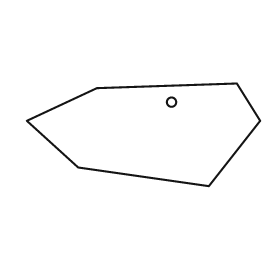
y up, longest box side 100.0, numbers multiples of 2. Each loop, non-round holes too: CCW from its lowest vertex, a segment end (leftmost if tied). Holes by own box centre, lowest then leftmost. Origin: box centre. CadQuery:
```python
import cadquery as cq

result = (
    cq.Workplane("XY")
    .moveTo(28.0, -22.0)
    .lineTo(50.0, 6.0)
    .lineTo(40.0, 22.0)
    .lineTo(-20.0, 20.0)
    .lineTo(-50.0, 6.0)
    .lineTo(-28.0, -14.0)
    .close()
    .moveTo(12.0, 14.0)
    .circle(2.0)
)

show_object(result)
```